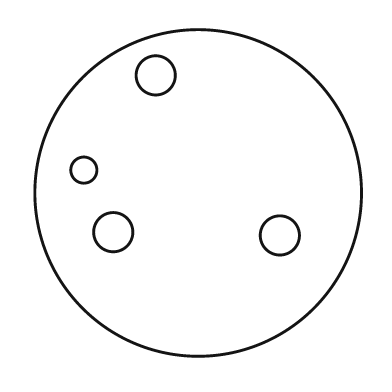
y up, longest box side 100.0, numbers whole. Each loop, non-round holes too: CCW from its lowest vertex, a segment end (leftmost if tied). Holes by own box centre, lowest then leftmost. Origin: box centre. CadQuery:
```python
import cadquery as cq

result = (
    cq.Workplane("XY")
    .moveTo(0.0, 0.0)
    .circle(50.0)
    .moveTo(25.0, -13.0)
    .circle(6.0)
    .moveTo(-26.0, -12.0)
    .circle(6.0)
    .moveTo(-35.0, 7.0)
    .circle(4.0)
    .moveTo(-13.0, 36.0)
    .circle(6.0)
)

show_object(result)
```